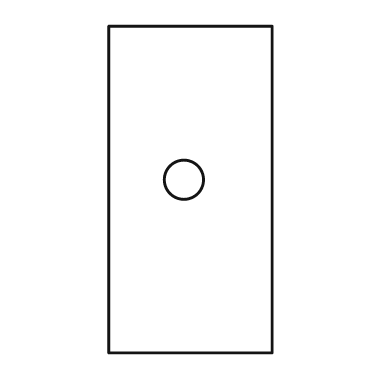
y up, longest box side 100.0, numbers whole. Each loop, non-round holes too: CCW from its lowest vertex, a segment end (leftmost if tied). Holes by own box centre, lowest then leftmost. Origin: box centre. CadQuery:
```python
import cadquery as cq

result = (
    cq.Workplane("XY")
    .moveTo(-25.0, -50.0)
    .lineTo(25.0, -50.0)
    .lineTo(25.0, 50.0)
    .lineTo(-25.0, 50.0)
    .close()
    .moveTo(-2.0, 3.0)
    .circle(6.0)
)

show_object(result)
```